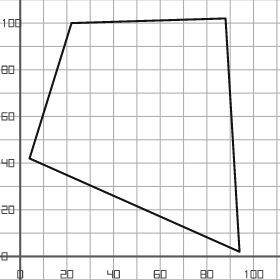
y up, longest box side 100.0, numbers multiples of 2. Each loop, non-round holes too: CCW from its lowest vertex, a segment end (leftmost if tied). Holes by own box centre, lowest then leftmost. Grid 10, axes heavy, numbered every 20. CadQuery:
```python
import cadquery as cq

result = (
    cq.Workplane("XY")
    .moveTo(94.0, 2.0)
    .lineTo(88.0, 102.0)
    .lineTo(22.0, 100.0)
    .lineTo(4.0, 42.0)
    .close()
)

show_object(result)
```